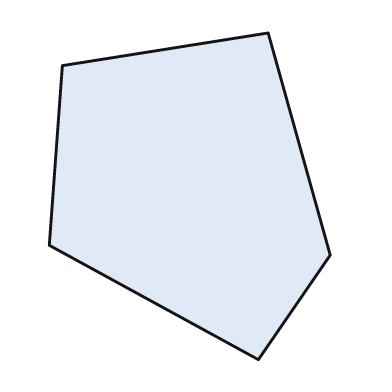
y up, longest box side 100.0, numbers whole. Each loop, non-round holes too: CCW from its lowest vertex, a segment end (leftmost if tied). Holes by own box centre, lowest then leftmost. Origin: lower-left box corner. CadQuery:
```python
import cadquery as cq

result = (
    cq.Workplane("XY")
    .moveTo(64.0, 0.0)
    .lineTo(86.0, 32.0)
    .lineTo(67.0, 100.0)
    .lineTo(4.0, 90.0)
    .lineTo(0.0, 35.0)
    .close()
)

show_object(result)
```